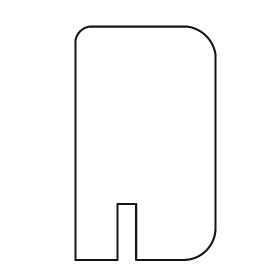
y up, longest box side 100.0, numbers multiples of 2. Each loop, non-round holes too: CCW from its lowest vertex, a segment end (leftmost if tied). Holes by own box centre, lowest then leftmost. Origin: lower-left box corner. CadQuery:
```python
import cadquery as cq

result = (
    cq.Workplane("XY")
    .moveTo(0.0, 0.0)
    .lineTo(18.0, 0.0)
    .lineTo(18.0, 24.0)
    .lineTo(26.0, 24.0)
    .lineTo(26.0, 0.0)
    .lineTo(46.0, 0.0)
    .threePointArc((56.0, 4.0), (60.0, 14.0))
    .lineTo(60.0, 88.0)
    .threePointArc((56.0, 96.0), (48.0, 100.0))
    .lineTo(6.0, 100.0)
    .threePointArc((2.0, 98.0), (0.0, 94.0))
    .close()
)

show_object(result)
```